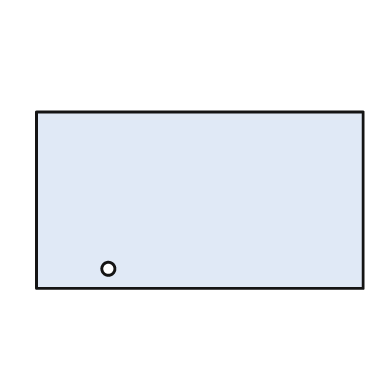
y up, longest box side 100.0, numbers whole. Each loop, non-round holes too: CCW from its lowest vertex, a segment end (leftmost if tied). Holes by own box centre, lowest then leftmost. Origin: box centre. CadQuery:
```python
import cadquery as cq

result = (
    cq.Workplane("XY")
    .moveTo(-50.0, -27.0)
    .lineTo(50.0, -27.0)
    .lineTo(50.0, 27.0)
    .lineTo(-50.0, 27.0)
    .close()
    .moveTo(-28.0, -21.0)
    .circle(2.0)
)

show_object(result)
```